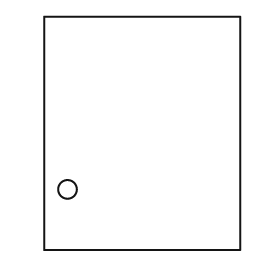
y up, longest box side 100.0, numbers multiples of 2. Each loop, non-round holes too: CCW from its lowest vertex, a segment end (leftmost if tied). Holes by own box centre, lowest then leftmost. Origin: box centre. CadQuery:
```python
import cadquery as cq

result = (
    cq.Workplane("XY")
    .moveTo(-42.0, -50.0)
    .lineTo(42.0, -50.0)
    .lineTo(42.0, 50.0)
    .lineTo(-42.0, 50.0)
    .close()
    .moveTo(-32.0, -24.0)
    .circle(4.0)
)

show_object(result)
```